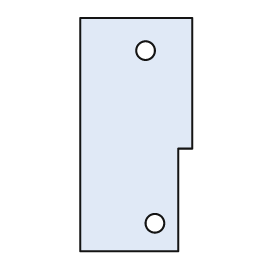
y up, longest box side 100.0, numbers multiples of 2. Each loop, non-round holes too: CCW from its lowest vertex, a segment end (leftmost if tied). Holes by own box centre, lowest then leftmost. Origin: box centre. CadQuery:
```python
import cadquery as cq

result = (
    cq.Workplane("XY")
    .moveTo(-24.0, -50.0)
    .lineTo(18.0, -50.0)
    .lineTo(18.0, -6.0)
    .lineTo(24.0, -6.0)
    .lineTo(24.0, 50.0)
    .lineTo(-24.0, 50.0)
    .close()
    .moveTo(8.0, -38.0)
    .circle(4.0)
    .moveTo(4.0, 36.0)
    .circle(4.0)
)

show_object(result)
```